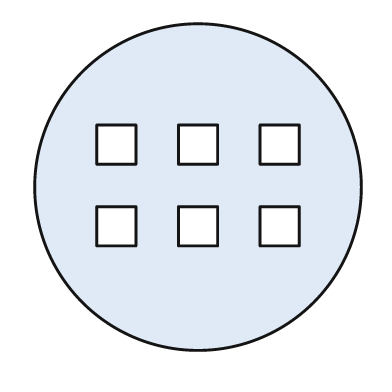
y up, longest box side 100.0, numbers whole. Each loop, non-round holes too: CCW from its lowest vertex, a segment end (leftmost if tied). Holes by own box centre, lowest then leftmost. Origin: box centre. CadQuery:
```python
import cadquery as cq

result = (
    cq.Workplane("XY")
    .moveTo(0.0, 0.0)
    .circle(50.0)
    .moveTo(-31.0, -18.0)
    .lineTo(-19.0, -18.0)
    .lineTo(-19.0, -6.0)
    .lineTo(-31.0, -6.0)
    .close()
    .moveTo(-6.0, -18.0)
    .lineTo(6.0, -18.0)
    .lineTo(6.0, -6.0)
    .lineTo(-6.0, -6.0)
    .close()
    .moveTo(19.0, -18.0)
    .lineTo(31.0, -18.0)
    .lineTo(31.0, -6.0)
    .lineTo(19.0, -6.0)
    .close()
    .moveTo(-31.0, 7.0)
    .lineTo(-19.0, 7.0)
    .lineTo(-19.0, 19.0)
    .lineTo(-31.0, 19.0)
    .close()
    .moveTo(-6.0, 7.0)
    .lineTo(6.0, 7.0)
    .lineTo(6.0, 19.0)
    .lineTo(-6.0, 19.0)
    .close()
    .moveTo(19.0, 7.0)
    .lineTo(31.0, 7.0)
    .lineTo(31.0, 19.0)
    .lineTo(19.0, 19.0)
    .close()
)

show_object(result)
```